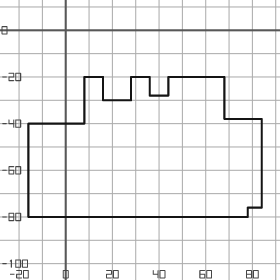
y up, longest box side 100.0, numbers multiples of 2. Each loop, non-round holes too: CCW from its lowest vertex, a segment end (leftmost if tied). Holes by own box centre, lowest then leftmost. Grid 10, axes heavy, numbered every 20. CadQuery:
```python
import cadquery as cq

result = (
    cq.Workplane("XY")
    .moveTo(-16.0, -80.0)
    .lineTo(78.0, -80.0)
    .lineTo(78.0, -76.0)
    .lineTo(84.0, -76.0)
    .lineTo(84.0, -38.0)
    .lineTo(68.0, -38.0)
    .lineTo(68.0, -20.0)
    .lineTo(44.0, -20.0)
    .lineTo(44.0, -28.0)
    .lineTo(36.0, -28.0)
    .lineTo(36.0, -20.0)
    .lineTo(28.0, -20.0)
    .lineTo(28.0, -30.0)
    .lineTo(16.0, -30.0)
    .lineTo(16.0, -20.0)
    .lineTo(8.0, -20.0)
    .lineTo(8.0, -40.0)
    .lineTo(-16.0, -40.0)
    .close()
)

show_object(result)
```